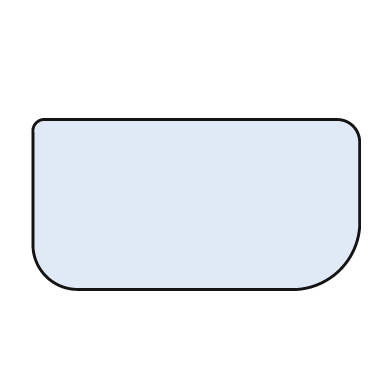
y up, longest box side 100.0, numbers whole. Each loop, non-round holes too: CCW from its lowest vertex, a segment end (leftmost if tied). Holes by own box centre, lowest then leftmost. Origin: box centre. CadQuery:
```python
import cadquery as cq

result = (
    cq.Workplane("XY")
    .moveTo(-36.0, -26.0)
    .lineTo(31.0, -26.0)
    .threePointArc((44.0, -20.0), (50.0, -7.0))
    .lineTo(50.0, 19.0)
    .threePointArc((48.0, 24.0), (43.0, 26.0))
    .lineTo(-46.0, 26.0)
    .threePointArc((-49.0, 25.0), (-50.0, 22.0))
    .lineTo(-50.0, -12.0)
    .threePointArc((-46.0, -22.0), (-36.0, -26.0))
    .close()
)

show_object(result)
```